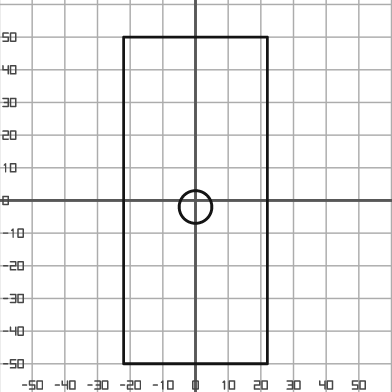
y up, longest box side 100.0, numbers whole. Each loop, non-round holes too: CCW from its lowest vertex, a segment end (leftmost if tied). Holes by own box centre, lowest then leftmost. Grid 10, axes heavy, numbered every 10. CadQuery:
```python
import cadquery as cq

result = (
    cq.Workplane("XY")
    .moveTo(-22.0, -50.0)
    .lineTo(22.0, -50.0)
    .lineTo(22.0, 50.0)
    .lineTo(-22.0, 50.0)
    .close()
    .moveTo(0.0, -2.0)
    .circle(5.0)
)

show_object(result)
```